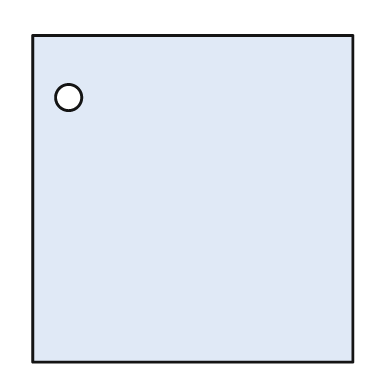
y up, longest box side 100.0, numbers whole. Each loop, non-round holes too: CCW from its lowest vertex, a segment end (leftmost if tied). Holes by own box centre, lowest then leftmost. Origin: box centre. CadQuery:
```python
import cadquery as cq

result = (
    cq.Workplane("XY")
    .moveTo(-49.0, -50.0)
    .lineTo(49.0, -50.0)
    .lineTo(49.0, 50.0)
    .lineTo(-49.0, 50.0)
    .close()
    .moveTo(-38.0, 31.0)
    .circle(4.0)
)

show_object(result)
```